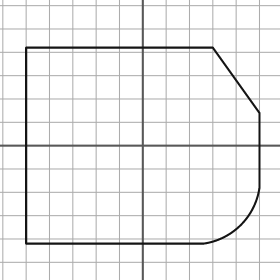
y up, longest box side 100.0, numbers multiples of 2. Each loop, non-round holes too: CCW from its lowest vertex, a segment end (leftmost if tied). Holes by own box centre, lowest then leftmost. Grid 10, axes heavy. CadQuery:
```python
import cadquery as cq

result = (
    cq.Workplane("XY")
    .moveTo(-50.0, -42.0)
    .lineTo(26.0, -42.0)
    .threePointArc((42.0, -34.0), (50.0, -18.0))
    .lineTo(50.0, 14.0)
    .lineTo(30.0, 42.0)
    .lineTo(-50.0, 42.0)
    .close()
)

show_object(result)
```